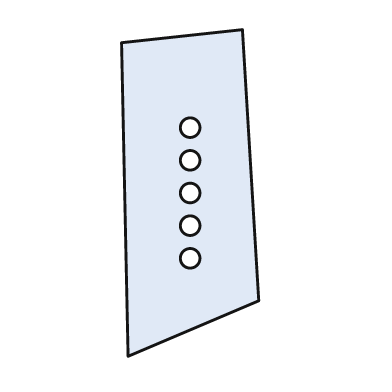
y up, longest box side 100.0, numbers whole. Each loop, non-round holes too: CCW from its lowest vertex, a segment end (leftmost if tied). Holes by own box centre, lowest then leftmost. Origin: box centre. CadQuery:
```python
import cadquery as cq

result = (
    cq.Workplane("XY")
    .moveTo(-19.0, -50.0)
    .lineTo(21.0, -33.0)
    .lineTo(16.0, 50.0)
    .lineTo(-21.0, 46.0)
    .close()
    .moveTo(0.0, -20.0)
    .circle(3.0)
    .moveTo(0.0, -10.0)
    .circle(3.0)
    .moveTo(0.0, 0.0)
    .circle(3.0)
    .moveTo(0.0, 10.0)
    .circle(3.0)
    .moveTo(0.0, 20.0)
    .circle(3.0)
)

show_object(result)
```